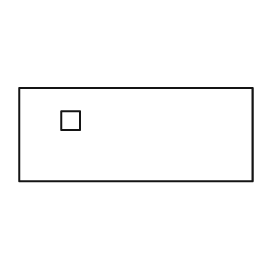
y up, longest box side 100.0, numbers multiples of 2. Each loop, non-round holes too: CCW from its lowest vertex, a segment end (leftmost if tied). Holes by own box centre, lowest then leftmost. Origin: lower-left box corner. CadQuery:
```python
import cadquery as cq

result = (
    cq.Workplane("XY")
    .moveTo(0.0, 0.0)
    .lineTo(100.0, 0.0)
    .lineTo(100.0, 40.0)
    .lineTo(0.0, 40.0)
    .close()
    .moveTo(18.0, 22.0)
    .lineTo(26.0, 22.0)
    .lineTo(26.0, 30.0)
    .lineTo(18.0, 30.0)
    .close()
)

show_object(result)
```